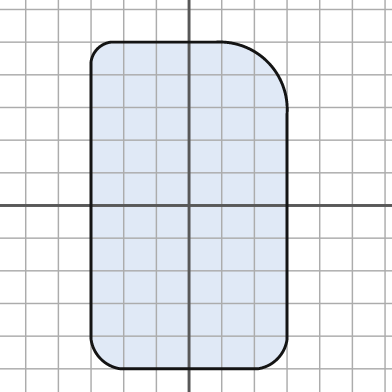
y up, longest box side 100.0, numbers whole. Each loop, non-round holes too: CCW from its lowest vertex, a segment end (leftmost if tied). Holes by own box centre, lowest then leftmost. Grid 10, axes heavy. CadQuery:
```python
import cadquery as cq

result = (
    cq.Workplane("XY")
    .moveTo(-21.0, -50.0)
    .lineTo(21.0, -50.0)
    .threePointArc((27.0, -47.0), (30.0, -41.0))
    .lineTo(30.0, 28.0)
    .threePointArc((24.0, 44.0), (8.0, 50.0))
    .lineTo(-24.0, 50.0)
    .threePointArc((-28.0, 48.0), (-30.0, 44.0))
    .lineTo(-30.0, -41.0)
    .threePointArc((-27.0, -47.0), (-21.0, -50.0))
    .close()
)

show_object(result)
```